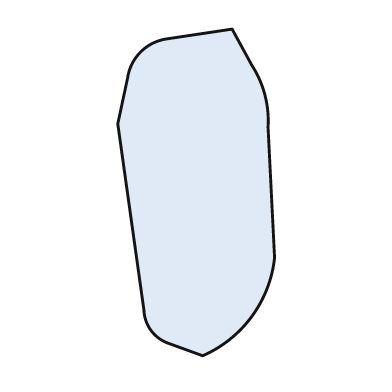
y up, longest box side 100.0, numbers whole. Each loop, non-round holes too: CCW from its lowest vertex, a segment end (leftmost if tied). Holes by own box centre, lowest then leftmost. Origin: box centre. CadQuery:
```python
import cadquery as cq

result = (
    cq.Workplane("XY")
    .moveTo(2.0, -50.0)
    .threePointArc((17.0, -38.0), (24.0, -20.0))
    .lineTo(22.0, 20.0)
    .threePointArc((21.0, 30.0), (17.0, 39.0))
    .lineTo(11.0, 50.0)
    .lineTo(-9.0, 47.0)
    .threePointArc((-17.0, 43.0), (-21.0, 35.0))
    .lineTo(-24.0, 21.0)
    .lineTo(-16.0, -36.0)
    .threePointArc((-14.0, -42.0), (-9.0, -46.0))
    .close()
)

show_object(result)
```